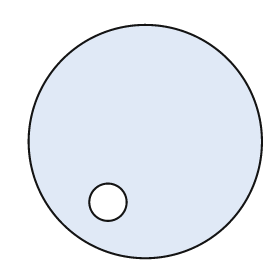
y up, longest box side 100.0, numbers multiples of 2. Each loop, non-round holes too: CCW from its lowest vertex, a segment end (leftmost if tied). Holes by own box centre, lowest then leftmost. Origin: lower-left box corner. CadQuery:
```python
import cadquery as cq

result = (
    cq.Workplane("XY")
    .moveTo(50.0, 50.0)
    .circle(50.0)
    .moveTo(34.0, 24.0)
    .circle(8.0)
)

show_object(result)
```